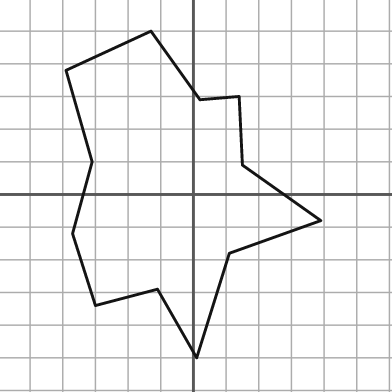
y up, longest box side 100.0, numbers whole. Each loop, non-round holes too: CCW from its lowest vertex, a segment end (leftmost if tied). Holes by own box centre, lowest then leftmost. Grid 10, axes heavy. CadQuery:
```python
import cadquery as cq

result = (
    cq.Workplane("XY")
    .moveTo(1.0, -50.0)
    .lineTo(11.0, -18.0)
    .lineTo(39.0, -8.0)
    .lineTo(15.0, 9.0)
    .lineTo(14.0, 30.0)
    .lineTo(2.0, 29.0)
    .lineTo(-13.0, 50.0)
    .lineTo(-39.0, 38.0)
    .lineTo(-31.0, 10.0)
    .lineTo(-37.0, -12.0)
    .lineTo(-30.0, -34.0)
    .lineTo(-11.0, -29.0)
    .close()
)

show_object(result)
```